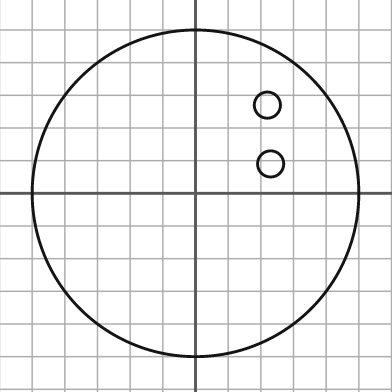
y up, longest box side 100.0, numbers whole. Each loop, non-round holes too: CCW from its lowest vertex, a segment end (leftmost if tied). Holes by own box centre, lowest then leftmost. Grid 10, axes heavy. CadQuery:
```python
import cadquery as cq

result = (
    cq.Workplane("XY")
    .moveTo(0.0, 0.0)
    .circle(50.0)
    .moveTo(23.0, 9.0)
    .circle(4.0)
    .moveTo(22.0, 27.0)
    .circle(4.0)
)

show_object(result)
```